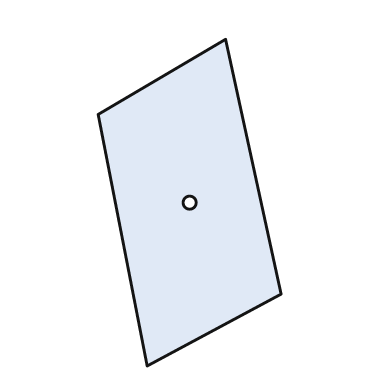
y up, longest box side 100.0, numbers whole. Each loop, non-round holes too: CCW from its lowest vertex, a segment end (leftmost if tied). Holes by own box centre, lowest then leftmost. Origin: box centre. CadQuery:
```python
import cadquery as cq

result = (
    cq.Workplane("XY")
    .moveTo(-13.0, -50.0)
    .lineTo(28.0, -28.0)
    .lineTo(11.0, 50.0)
    .lineTo(-28.0, 27.0)
    .close()
    .moveTo(0.0, 0.0)
    .circle(2.0)
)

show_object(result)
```